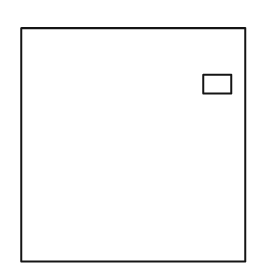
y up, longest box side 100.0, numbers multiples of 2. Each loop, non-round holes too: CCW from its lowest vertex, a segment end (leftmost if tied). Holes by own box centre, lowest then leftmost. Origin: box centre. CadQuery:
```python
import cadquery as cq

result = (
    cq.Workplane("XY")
    .moveTo(-48.0, -50.0)
    .lineTo(48.0, -50.0)
    .lineTo(48.0, 50.0)
    .lineTo(-48.0, 50.0)
    .close()
    .moveTo(30.0, 22.0)
    .lineTo(42.0, 22.0)
    .lineTo(42.0, 30.0)
    .lineTo(30.0, 30.0)
    .close()
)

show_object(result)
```